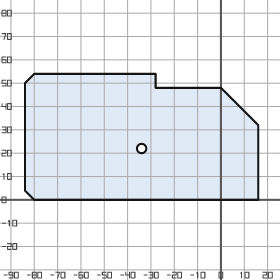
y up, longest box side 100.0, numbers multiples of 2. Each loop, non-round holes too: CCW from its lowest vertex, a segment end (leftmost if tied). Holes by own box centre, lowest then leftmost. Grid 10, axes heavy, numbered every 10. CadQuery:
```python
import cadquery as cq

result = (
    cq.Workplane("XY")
    .moveTo(-80.0, 0.0)
    .lineTo(16.0, 0.0)
    .lineTo(16.0, 32.0)
    .lineTo(0.0, 48.0)
    .lineTo(-28.0, 48.0)
    .lineTo(-28.0, 54.0)
    .lineTo(-80.0, 54.0)
    .lineTo(-84.0, 50.0)
    .lineTo(-84.0, 4.0)
    .close()
    .moveTo(-34.0, 22.0)
    .circle(2.0)
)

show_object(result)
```